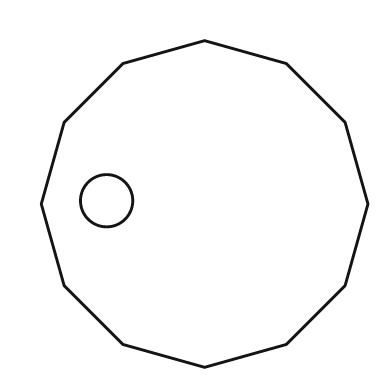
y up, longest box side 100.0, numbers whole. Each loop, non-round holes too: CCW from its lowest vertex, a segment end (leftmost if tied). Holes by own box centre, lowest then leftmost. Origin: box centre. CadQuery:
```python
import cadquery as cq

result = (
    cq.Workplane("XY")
    .moveTo(0.0, -50.0)
    .lineTo(25.0, -43.0)
    .lineTo(43.0, -25.0)
    .lineTo(50.0, 0.0)
    .lineTo(43.0, 25.0)
    .lineTo(25.0, 43.0)
    .lineTo(0.0, 50.0)
    .lineTo(-25.0, 43.0)
    .lineTo(-43.0, 25.0)
    .lineTo(-50.0, 0.0)
    .lineTo(-43.0, -25.0)
    .lineTo(-25.0, -43.0)
    .close()
    .moveTo(-30.0, 1.0)
    .circle(8.0)
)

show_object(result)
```